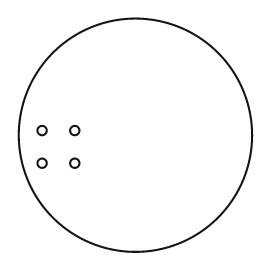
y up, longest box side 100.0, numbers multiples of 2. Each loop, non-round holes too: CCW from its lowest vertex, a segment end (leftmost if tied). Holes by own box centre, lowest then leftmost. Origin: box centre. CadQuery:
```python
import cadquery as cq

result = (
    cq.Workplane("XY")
    .moveTo(0.0, 0.0)
    .circle(50.0)
    .moveTo(-40.0, -12.0)
    .circle(2.0)
    .moveTo(-26.0, -12.0)
    .circle(2.0)
    .moveTo(-40.0, 2.0)
    .circle(2.0)
    .moveTo(-26.0, 2.0)
    .circle(2.0)
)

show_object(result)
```